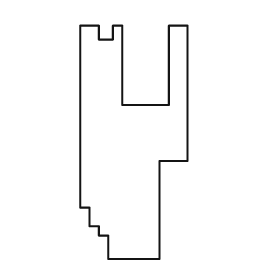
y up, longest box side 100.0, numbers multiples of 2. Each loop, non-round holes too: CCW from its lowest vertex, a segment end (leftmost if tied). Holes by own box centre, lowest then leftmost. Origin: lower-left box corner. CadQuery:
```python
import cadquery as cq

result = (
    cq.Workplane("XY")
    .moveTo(12.0, 0.0)
    .lineTo(34.0, 0.0)
    .lineTo(34.0, 42.0)
    .lineTo(46.0, 42.0)
    .lineTo(46.0, 100.0)
    .lineTo(38.0, 100.0)
    .lineTo(38.0, 66.0)
    .lineTo(18.0, 66.0)
    .lineTo(18.0, 100.0)
    .lineTo(14.0, 100.0)
    .lineTo(14.0, 94.0)
    .lineTo(8.0, 94.0)
    .lineTo(8.0, 100.0)
    .lineTo(0.0, 100.0)
    .lineTo(0.0, 22.0)
    .lineTo(4.0, 22.0)
    .lineTo(4.0, 14.0)
    .lineTo(8.0, 14.0)
    .lineTo(8.0, 10.0)
    .lineTo(12.0, 10.0)
    .close()
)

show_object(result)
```